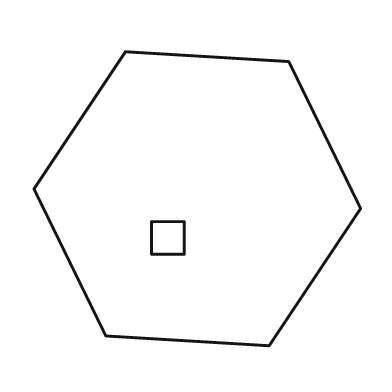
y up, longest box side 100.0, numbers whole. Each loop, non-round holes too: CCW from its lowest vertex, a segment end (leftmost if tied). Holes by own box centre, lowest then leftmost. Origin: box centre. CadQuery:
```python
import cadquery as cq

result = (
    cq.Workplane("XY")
    .moveTo(22.0, -45.0)
    .lineTo(50.0, -3.0)
    .lineTo(28.0, 42.0)
    .lineTo(-22.0, 45.0)
    .lineTo(-50.0, 3.0)
    .lineTo(-28.0, -42.0)
    .close()
    .moveTo(-14.0, -17.0)
    .lineTo(-4.0, -17.0)
    .lineTo(-4.0, -7.0)
    .lineTo(-14.0, -7.0)
    .close()
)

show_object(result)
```